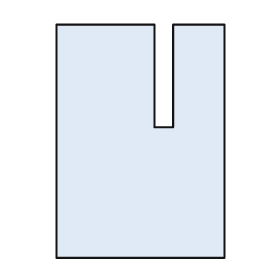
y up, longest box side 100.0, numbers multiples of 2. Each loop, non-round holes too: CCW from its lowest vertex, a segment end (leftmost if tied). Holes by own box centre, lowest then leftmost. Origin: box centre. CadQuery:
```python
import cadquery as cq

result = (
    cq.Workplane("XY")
    .moveTo(-36.0, -50.0)
    .lineTo(36.0, -50.0)
    .lineTo(36.0, 50.0)
    .lineTo(14.0, 50.0)
    .lineTo(14.0, 6.0)
    .lineTo(6.0, 6.0)
    .lineTo(6.0, 50.0)
    .lineTo(-36.0, 50.0)
    .close()
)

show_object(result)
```